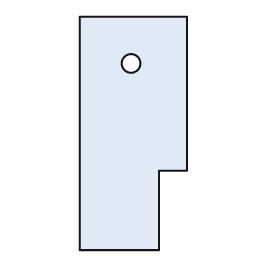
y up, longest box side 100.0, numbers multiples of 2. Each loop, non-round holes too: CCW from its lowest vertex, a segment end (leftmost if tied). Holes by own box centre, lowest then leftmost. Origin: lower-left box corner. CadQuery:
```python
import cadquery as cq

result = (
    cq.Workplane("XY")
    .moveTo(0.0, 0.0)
    .lineTo(34.0, 0.0)
    .lineTo(34.0, 34.0)
    .lineTo(46.0, 34.0)
    .lineTo(46.0, 100.0)
    .lineTo(0.0, 100.0)
    .close()
    .moveTo(22.0, 80.0)
    .circle(4.0)
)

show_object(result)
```